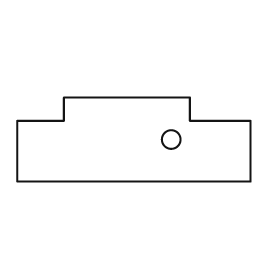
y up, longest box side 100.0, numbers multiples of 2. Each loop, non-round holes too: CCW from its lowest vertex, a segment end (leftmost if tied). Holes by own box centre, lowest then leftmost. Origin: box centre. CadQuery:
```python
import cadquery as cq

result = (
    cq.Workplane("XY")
    .moveTo(-50.0, -18.0)
    .lineTo(50.0, -18.0)
    .lineTo(50.0, 8.0)
    .lineTo(24.0, 8.0)
    .lineTo(24.0, 18.0)
    .lineTo(-30.0, 18.0)
    .lineTo(-30.0, 8.0)
    .lineTo(-50.0, 8.0)
    .close()
    .moveTo(16.0, 0.0)
    .circle(4.0)
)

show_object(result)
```